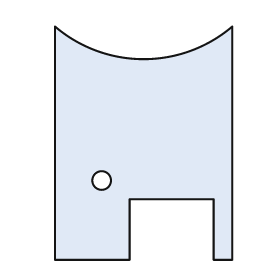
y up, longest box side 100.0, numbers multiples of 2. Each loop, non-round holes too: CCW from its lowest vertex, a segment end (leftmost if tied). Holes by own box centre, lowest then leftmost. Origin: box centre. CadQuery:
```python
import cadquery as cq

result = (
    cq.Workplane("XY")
    .moveTo(-38.0, -50.0)
    .lineTo(-6.0, -50.0)
    .lineTo(-6.0, -24.0)
    .lineTo(30.0, -24.0)
    .lineTo(30.0, -50.0)
    .lineTo(38.0, -50.0)
    .lineTo(38.0, 50.0)
    .threePointArc((0.0, 36.0), (-38.0, 50.0))
    .close()
    .moveTo(-18.0, -16.0)
    .circle(4.0)
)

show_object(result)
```